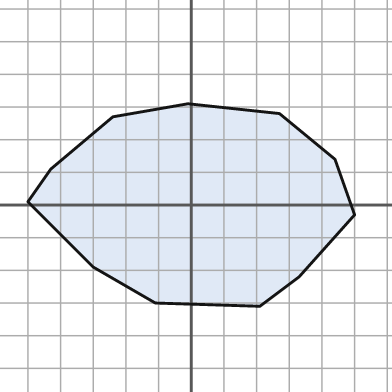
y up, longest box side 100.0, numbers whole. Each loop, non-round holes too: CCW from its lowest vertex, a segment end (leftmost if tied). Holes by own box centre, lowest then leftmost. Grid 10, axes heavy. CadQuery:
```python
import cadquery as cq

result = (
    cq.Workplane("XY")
    .moveTo(21.0, -31.0)
    .lineTo(33.0, -22.0)
    .lineTo(50.0, -3.0)
    .lineTo(44.0, 14.0)
    .lineTo(27.0, 28.0)
    .lineTo(-1.0, 31.0)
    .lineTo(-24.0, 27.0)
    .lineTo(-43.0, 11.0)
    .lineTo(-50.0, 1.0)
    .lineTo(-30.0, -19.0)
    .lineTo(-11.0, -30.0)
    .close()
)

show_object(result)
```